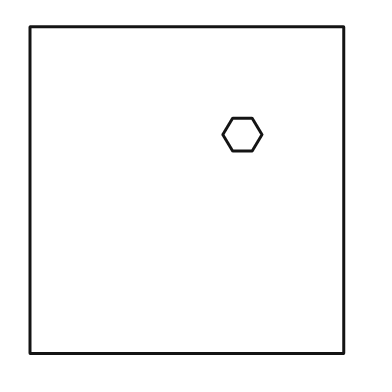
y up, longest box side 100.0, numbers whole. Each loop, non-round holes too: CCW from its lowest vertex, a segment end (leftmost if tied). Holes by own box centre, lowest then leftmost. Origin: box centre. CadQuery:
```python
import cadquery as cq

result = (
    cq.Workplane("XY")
    .moveTo(-48.0, -50.0)
    .lineTo(48.0, -50.0)
    .lineTo(48.0, 50.0)
    .lineTo(-48.0, 50.0)
    .close()
    .moveTo(14.0, 12.0)
    .lineTo(20.0, 12.0)
    .lineTo(23.0, 17.0)
    .lineTo(20.0, 22.0)
    .lineTo(14.0, 22.0)
    .lineTo(11.0, 17.0)
    .close()
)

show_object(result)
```